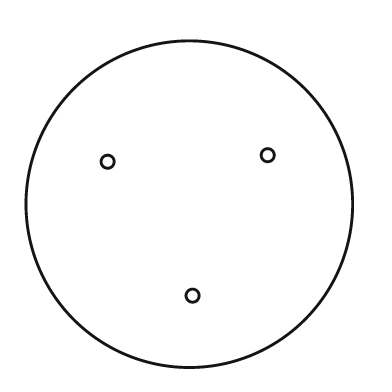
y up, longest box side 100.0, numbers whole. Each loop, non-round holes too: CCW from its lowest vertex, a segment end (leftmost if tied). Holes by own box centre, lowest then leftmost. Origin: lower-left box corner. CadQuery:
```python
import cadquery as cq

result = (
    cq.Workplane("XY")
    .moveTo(50.0, 50.0)
    .circle(50.0)
    .moveTo(51.0, 22.0)
    .circle(2.0)
    .moveTo(25.0, 63.0)
    .circle(2.0)
    .moveTo(74.0, 65.0)
    .circle(2.0)
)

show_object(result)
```